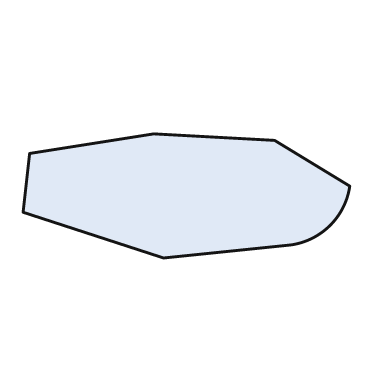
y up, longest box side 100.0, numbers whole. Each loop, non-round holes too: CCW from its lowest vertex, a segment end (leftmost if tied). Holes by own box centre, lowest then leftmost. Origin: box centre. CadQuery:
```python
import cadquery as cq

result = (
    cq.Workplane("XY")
    .moveTo(-7.0, -19.0)
    .lineTo(32.0, -15.0)
    .threePointArc((44.0, -9.0), (50.0, 3.0))
    .lineTo(27.0, 17.0)
    .lineTo(-10.0, 19.0)
    .lineTo(-48.0, 13.0)
    .lineTo(-50.0, -5.0)
    .close()
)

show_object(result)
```